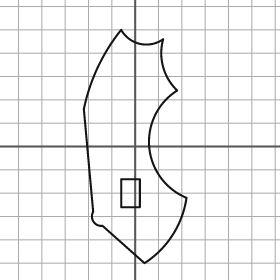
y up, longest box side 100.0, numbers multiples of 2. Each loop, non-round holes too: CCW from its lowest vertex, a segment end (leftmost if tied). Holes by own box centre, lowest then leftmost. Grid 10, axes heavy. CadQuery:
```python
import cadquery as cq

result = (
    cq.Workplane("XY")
    .moveTo(4.0, -50.0)
    .threePointArc((16.0, -38.0), (22.0, -22.0))
    .threePointArc((6.0, 0.0), (18.0, 24.0))
    .threePointArc((12.0, 34.0), (12.0, 46.0))
    .threePointArc((2.0, 44.0), (-6.0, 50.0))
    .threePointArc((-16.0, 34.0), (-22.0, 16.0))
    .lineTo(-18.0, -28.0)
    .threePointArc((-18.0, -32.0), (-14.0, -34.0))
    .close()
    .moveTo(-6.0, -26.0)
    .lineTo(2.0, -26.0)
    .lineTo(2.0, -14.0)
    .lineTo(-6.0, -14.0)
    .close()
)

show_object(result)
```